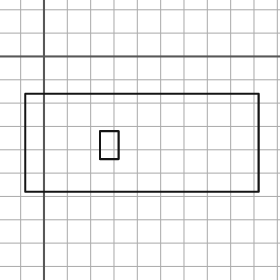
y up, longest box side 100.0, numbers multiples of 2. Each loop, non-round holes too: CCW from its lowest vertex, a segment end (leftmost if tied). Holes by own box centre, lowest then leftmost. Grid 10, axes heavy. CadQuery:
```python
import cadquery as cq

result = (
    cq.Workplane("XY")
    .moveTo(-8.0, -58.0)
    .lineTo(92.0, -58.0)
    .lineTo(92.0, -16.0)
    .lineTo(-8.0, -16.0)
    .close()
    .moveTo(24.0, -44.0)
    .lineTo(32.0, -44.0)
    .lineTo(32.0, -32.0)
    .lineTo(24.0, -32.0)
    .close()
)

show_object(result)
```